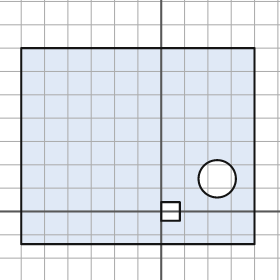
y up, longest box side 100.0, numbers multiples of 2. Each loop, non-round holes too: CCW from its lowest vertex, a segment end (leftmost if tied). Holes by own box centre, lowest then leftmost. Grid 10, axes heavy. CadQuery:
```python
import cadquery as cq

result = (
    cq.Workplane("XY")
    .moveTo(-60.0, -14.0)
    .lineTo(40.0, -14.0)
    .lineTo(40.0, 70.0)
    .lineTo(-60.0, 70.0)
    .close()
    .moveTo(0.0, -4.0)
    .lineTo(8.0, -4.0)
    .lineTo(8.0, 4.0)
    .lineTo(0.0, 4.0)
    .close()
    .moveTo(24.0, 14.0)
    .circle(8.0)
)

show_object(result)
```